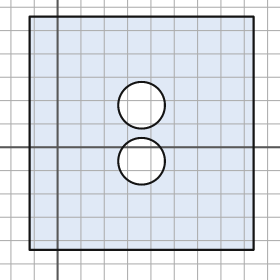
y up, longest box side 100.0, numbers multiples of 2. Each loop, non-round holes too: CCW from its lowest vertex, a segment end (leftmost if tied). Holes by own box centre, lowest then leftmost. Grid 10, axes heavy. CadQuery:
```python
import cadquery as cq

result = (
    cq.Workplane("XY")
    .moveTo(-12.0, -44.0)
    .lineTo(84.0, -44.0)
    .lineTo(84.0, 56.0)
    .lineTo(-12.0, 56.0)
    .close()
    .moveTo(36.0, -6.0)
    .circle(10.0)
    .moveTo(36.0, 18.0)
    .circle(10.0)
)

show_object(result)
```